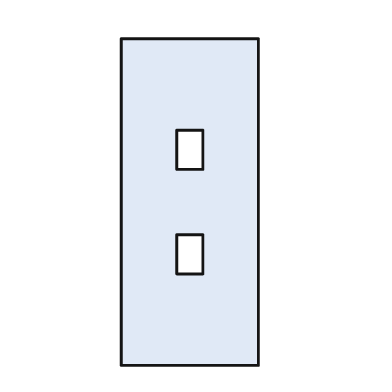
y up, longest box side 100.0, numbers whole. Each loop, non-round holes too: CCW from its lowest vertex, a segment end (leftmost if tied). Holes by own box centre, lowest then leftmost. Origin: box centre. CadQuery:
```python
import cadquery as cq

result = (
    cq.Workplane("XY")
    .moveTo(-21.0, -50.0)
    .lineTo(21.0, -50.0)
    .lineTo(21.0, 50.0)
    .lineTo(-21.0, 50.0)
    .close()
    .moveTo(-4.0, -22.0)
    .lineTo(4.0, -22.0)
    .lineTo(4.0, -10.0)
    .lineTo(-4.0, -10.0)
    .close()
    .moveTo(-4.0, 10.0)
    .lineTo(4.0, 10.0)
    .lineTo(4.0, 22.0)
    .lineTo(-4.0, 22.0)
    .close()
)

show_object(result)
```